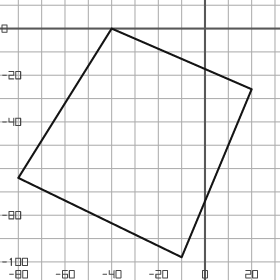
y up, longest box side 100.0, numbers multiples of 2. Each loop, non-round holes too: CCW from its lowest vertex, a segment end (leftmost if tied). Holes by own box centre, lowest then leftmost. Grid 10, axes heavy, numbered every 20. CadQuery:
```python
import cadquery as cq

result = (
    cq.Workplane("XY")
    .moveTo(-10.0, -98.0)
    .lineTo(20.0, -26.0)
    .lineTo(-40.0, 0.0)
    .lineTo(-80.0, -64.0)
    .close()
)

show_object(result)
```